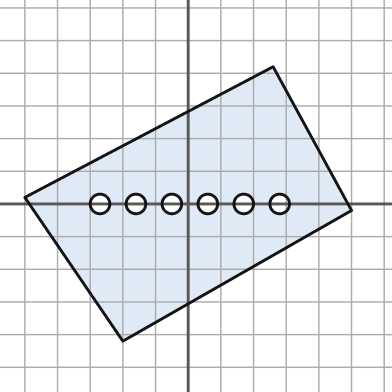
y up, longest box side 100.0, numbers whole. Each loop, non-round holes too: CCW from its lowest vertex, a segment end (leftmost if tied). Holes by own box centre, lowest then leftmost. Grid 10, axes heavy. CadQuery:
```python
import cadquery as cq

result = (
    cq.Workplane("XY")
    .moveTo(-20.0, -42.0)
    .lineTo(50.0, -2.0)
    .lineTo(26.0, 42.0)
    .lineTo(-50.0, 2.0)
    .close()
    .moveTo(-27.0, 0.0)
    .circle(3.0)
    .moveTo(-16.0, 0.0)
    .circle(3.0)
    .moveTo(-5.0, 0.0)
    .circle(3.0)
    .moveTo(6.0, 0.0)
    .circle(3.0)
    .moveTo(17.0, 0.0)
    .circle(3.0)
    .moveTo(28.0, 0.0)
    .circle(3.0)
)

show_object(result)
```